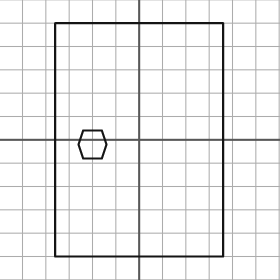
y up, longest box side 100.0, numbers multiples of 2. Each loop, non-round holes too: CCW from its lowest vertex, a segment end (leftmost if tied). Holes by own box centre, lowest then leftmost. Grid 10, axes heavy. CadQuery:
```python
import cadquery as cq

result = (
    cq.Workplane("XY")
    .moveTo(-36.0, -50.0)
    .lineTo(36.0, -50.0)
    .lineTo(36.0, 50.0)
    .lineTo(-36.0, 50.0)
    .close()
    .moveTo(-24.0, -8.0)
    .lineTo(-16.0, -8.0)
    .lineTo(-14.0, -2.0)
    .lineTo(-16.0, 4.0)
    .lineTo(-24.0, 4.0)
    .lineTo(-26.0, -2.0)
    .close()
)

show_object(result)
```